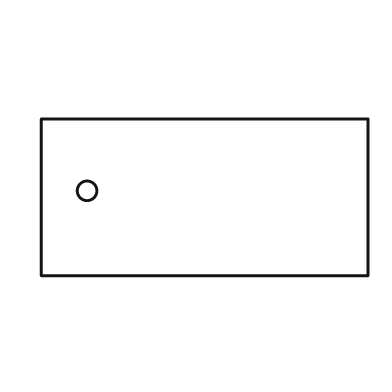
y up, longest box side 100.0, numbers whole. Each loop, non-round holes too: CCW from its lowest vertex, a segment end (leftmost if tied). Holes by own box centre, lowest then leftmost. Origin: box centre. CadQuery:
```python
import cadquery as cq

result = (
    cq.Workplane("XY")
    .moveTo(-50.0, -24.0)
    .lineTo(50.0, -24.0)
    .lineTo(50.0, 24.0)
    .lineTo(-50.0, 24.0)
    .close()
    .moveTo(-36.0, 2.0)
    .circle(3.0)
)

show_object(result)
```